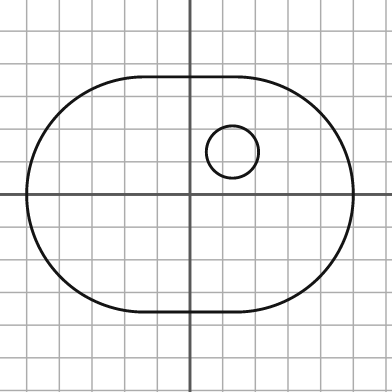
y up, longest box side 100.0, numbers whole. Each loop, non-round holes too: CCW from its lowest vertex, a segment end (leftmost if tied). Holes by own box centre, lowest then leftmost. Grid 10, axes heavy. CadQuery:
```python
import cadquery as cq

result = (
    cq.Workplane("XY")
    .moveTo(-14.0, -36.0)
    .lineTo(14.0, -36.0)
    .threePointArc((50.0, 0.0), (14.0, 36.0))
    .lineTo(-14.0, 36.0)
    .threePointArc((-50.0, 0.0), (-14.0, -36.0))
    .close()
    .moveTo(13.0, 13.0)
    .circle(8.0)
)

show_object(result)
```